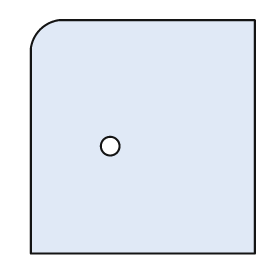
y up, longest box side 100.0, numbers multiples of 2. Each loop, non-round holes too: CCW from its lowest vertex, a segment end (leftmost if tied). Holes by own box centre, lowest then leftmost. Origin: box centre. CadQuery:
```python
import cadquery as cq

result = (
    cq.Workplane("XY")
    .moveTo(-48.0, -50.0)
    .lineTo(48.0, -50.0)
    .lineTo(48.0, 50.0)
    .lineTo(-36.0, 50.0)
    .threePointArc((-44.0, 46.0), (-48.0, 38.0))
    .close()
    .moveTo(-14.0, -4.0)
    .circle(4.0)
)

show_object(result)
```